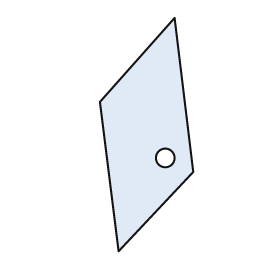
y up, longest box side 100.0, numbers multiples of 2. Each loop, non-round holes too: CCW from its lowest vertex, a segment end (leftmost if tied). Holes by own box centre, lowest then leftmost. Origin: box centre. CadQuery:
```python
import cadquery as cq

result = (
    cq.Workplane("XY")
    .moveTo(-12.0, -50.0)
    .lineTo(20.0, -16.0)
    .lineTo(12.0, 50.0)
    .lineTo(-20.0, 14.0)
    .close()
    .moveTo(8.0, -10.0)
    .circle(4.0)
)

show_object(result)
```